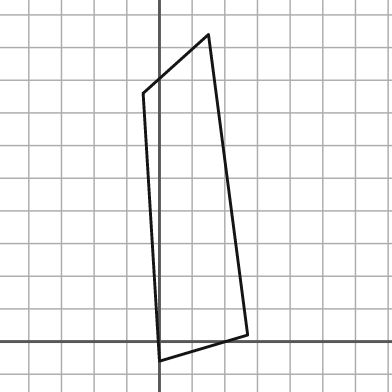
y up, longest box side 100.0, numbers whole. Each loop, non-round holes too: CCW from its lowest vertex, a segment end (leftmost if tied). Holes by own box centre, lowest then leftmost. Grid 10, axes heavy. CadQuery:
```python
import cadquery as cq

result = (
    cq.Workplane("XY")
    .moveTo(0.0, -6.0)
    .lineTo(27.0, 2.0)
    .lineTo(15.0, 94.0)
    .lineTo(-5.0, 76.0)
    .close()
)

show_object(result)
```